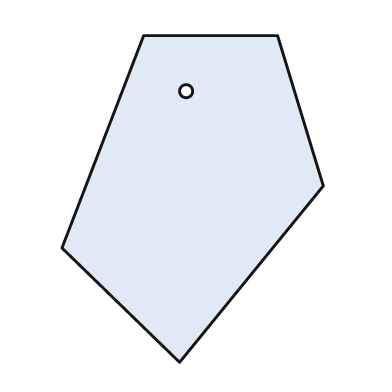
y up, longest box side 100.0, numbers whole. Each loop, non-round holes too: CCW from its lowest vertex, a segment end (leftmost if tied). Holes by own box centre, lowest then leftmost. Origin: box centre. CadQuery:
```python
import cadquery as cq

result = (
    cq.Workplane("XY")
    .moveTo(-4.0, -50.0)
    .lineTo(40.0, 4.0)
    .lineTo(26.0, 50.0)
    .lineTo(-15.0, 50.0)
    .lineTo(-40.0, -15.0)
    .close()
    .moveTo(-2.0, 33.0)
    .circle(2.0)
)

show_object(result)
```